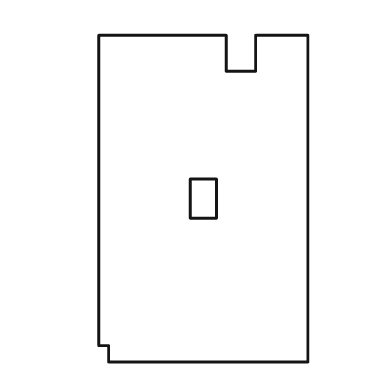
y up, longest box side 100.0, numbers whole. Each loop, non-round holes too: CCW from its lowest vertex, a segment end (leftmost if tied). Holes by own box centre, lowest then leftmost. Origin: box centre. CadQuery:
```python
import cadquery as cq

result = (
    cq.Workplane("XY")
    .moveTo(-29.0, -50.0)
    .lineTo(32.0, -50.0)
    .lineTo(32.0, 50.0)
    .lineTo(16.0, 50.0)
    .lineTo(16.0, 39.0)
    .lineTo(7.0, 39.0)
    .lineTo(7.0, 50.0)
    .lineTo(-32.0, 50.0)
    .lineTo(-32.0, -45.0)
    .lineTo(-29.0, -45.0)
    .close()
    .moveTo(-4.0, -6.0)
    .lineTo(4.0, -6.0)
    .lineTo(4.0, 6.0)
    .lineTo(-4.0, 6.0)
    .close()
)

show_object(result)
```